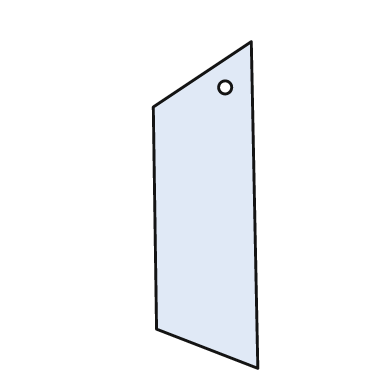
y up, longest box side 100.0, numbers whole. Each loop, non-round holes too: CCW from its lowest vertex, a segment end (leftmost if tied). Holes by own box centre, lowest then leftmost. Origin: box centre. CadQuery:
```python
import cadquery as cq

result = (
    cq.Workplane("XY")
    .moveTo(16.0, -50.0)
    .lineTo(14.0, 50.0)
    .lineTo(-16.0, 30.0)
    .lineTo(-15.0, -38.0)
    .close()
    .moveTo(6.0, 36.0)
    .circle(2.0)
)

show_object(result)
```